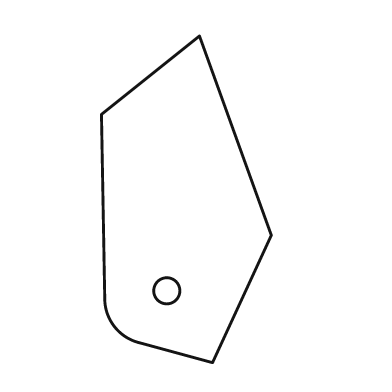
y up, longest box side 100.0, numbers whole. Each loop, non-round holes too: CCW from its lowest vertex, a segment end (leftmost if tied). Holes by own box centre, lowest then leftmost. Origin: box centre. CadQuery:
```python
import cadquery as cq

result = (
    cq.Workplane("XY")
    .moveTo(8.0, -50.0)
    .lineTo(26.0, -11.0)
    .lineTo(4.0, 50.0)
    .lineTo(-26.0, 26.0)
    .lineTo(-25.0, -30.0)
    .threePointArc((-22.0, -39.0), (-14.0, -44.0))
    .close()
    .moveTo(-6.0, -28.0)
    .circle(4.0)
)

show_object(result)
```